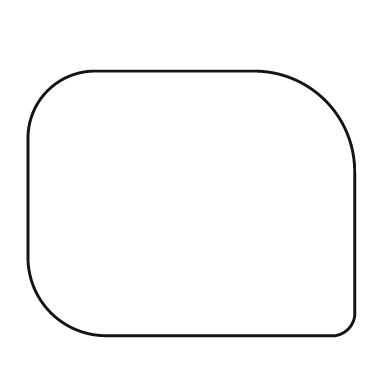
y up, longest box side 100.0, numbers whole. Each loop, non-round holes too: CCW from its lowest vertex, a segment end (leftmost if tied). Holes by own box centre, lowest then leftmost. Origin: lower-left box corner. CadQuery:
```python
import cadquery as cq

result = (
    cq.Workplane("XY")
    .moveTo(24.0, 0.0)
    .lineTo(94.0, 0.0)
    .threePointArc((98.0, 2.0), (100.0, 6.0))
    .lineTo(100.0, 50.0)
    .threePointArc((91.0, 72.0), (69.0, 81.0))
    .lineTo(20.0, 81.0)
    .threePointArc((6.0, 75.0), (0.0, 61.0))
    .lineTo(0.0, 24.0)
    .threePointArc((7.0, 7.0), (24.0, 0.0))
    .close()
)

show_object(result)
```